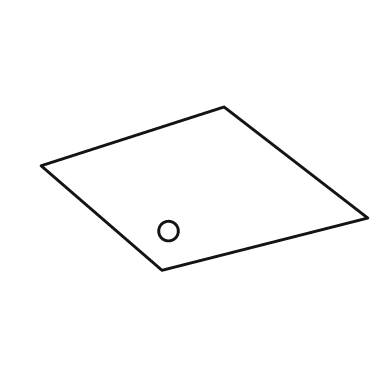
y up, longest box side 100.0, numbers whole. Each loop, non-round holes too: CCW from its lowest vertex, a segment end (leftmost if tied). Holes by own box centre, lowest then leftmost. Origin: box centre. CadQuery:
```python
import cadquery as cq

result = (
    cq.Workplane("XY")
    .moveTo(-13.0, -25.0)
    .lineTo(50.0, -9.0)
    .lineTo(6.0, 25.0)
    .lineTo(-50.0, 7.0)
    .close()
    .moveTo(-11.0, -13.0)
    .circle(3.0)
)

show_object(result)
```